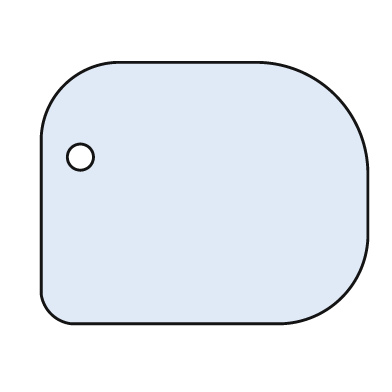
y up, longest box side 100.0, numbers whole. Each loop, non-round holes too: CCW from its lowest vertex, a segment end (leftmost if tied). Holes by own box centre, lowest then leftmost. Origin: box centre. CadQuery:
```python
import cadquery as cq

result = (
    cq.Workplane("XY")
    .moveTo(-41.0, -40.0)
    .lineTo(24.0, -40.0)
    .threePointArc((42.0, -32.0), (50.0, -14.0))
    .lineTo(50.0, 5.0)
    .threePointArc((40.0, 30.0), (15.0, 40.0))
    .lineTo(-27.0, 40.0)
    .threePointArc((-43.0, 33.0), (-50.0, 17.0))
    .lineTo(-50.0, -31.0)
    .threePointArc((-47.0, -37.0), (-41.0, -40.0))
    .close()
    .moveTo(-38.0, 11.0)
    .circle(4.0)
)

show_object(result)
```